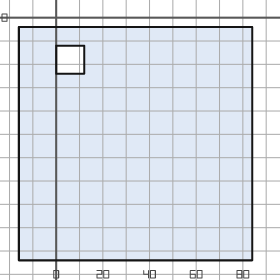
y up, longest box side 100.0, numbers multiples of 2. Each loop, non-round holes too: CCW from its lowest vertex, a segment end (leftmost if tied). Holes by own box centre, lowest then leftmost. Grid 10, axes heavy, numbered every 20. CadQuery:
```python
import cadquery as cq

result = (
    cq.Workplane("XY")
    .moveTo(-16.0, -104.0)
    .lineTo(84.0, -104.0)
    .lineTo(84.0, -4.0)
    .lineTo(-16.0, -4.0)
    .close()
    .moveTo(0.0, -24.0)
    .lineTo(12.0, -24.0)
    .lineTo(12.0, -12.0)
    .lineTo(0.0, -12.0)
    .close()
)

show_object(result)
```